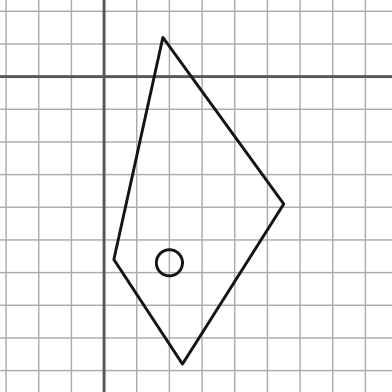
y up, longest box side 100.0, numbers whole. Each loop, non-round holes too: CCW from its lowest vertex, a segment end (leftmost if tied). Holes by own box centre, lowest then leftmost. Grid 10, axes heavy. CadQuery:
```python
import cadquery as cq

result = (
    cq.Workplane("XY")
    .moveTo(24.0, -88.0)
    .lineTo(55.0, -39.0)
    .lineTo(18.0, 12.0)
    .lineTo(3.0, -56.0)
    .close()
    .moveTo(20.0, -57.0)
    .circle(4.0)
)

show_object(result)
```